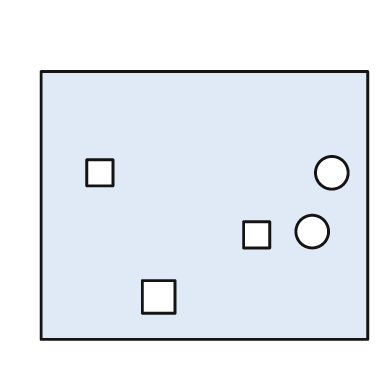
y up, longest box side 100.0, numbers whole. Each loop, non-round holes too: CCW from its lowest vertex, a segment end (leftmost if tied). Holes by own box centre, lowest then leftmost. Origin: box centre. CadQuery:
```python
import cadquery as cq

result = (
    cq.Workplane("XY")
    .moveTo(-50.0, -41.0)
    .lineTo(50.0, -41.0)
    .lineTo(50.0, 41.0)
    .lineTo(-50.0, 41.0)
    .close()
    .moveTo(-19.0, -33.0)
    .lineTo(-9.0, -33.0)
    .lineTo(-9.0, -23.0)
    .lineTo(-19.0, -23.0)
    .close()
    .moveTo(12.0, -13.0)
    .lineTo(20.0, -13.0)
    .lineTo(20.0, -5.0)
    .lineTo(12.0, -5.0)
    .close()
    .moveTo(33.0, -8.0)
    .circle(5.0)
    .moveTo(-36.0, 6.0)
    .lineTo(-28.0, 6.0)
    .lineTo(-28.0, 14.0)
    .lineTo(-36.0, 14.0)
    .close()
    .moveTo(39.0, 10.0)
    .circle(5.0)
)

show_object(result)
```